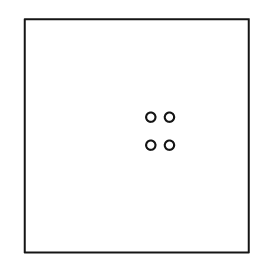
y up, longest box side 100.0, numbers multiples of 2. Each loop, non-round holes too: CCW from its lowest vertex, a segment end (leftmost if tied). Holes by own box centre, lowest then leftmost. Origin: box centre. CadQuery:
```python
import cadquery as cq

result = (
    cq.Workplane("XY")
    .moveTo(-48.0, -50.0)
    .lineTo(48.0, -50.0)
    .lineTo(48.0, 50.0)
    .lineTo(-48.0, 50.0)
    .close()
    .moveTo(6.0, -4.0)
    .circle(2.0)
    .moveTo(14.0, -4.0)
    .circle(2.0)
    .moveTo(6.0, 8.0)
    .circle(2.0)
    .moveTo(14.0, 8.0)
    .circle(2.0)
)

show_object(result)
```